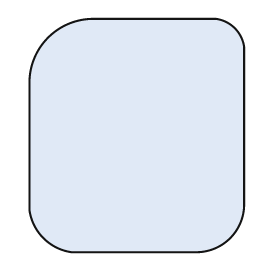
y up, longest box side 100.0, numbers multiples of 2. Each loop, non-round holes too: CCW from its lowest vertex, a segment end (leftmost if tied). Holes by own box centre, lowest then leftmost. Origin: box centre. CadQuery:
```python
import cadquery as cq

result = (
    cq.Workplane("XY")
    .moveTo(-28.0, -50.0)
    .lineTo(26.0, -50.0)
    .threePointArc((40.0, -44.0), (46.0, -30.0))
    .lineTo(46.0, 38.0)
    .threePointArc((42.0, 46.0), (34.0, 50.0))
    .lineTo(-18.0, 50.0)
    .threePointArc((-38.0, 42.0), (-46.0, 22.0))
    .lineTo(-46.0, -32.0)
    .threePointArc((-40.0, -44.0), (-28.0, -50.0))
    .close()
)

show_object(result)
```